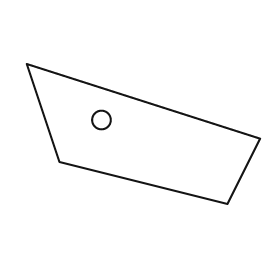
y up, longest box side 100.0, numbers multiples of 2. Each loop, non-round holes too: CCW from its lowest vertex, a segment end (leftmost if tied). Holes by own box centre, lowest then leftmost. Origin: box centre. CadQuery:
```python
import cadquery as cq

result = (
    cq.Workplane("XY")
    .moveTo(36.0, -30.0)
    .lineTo(50.0, -2.0)
    .lineTo(-50.0, 30.0)
    .lineTo(-36.0, -12.0)
    .close()
    .moveTo(-18.0, 6.0)
    .circle(4.0)
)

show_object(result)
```